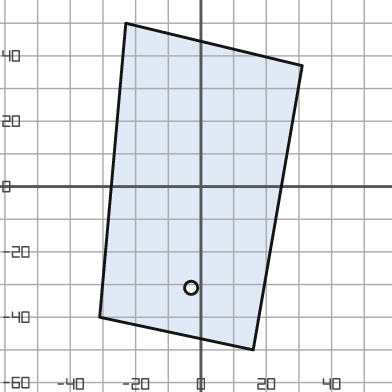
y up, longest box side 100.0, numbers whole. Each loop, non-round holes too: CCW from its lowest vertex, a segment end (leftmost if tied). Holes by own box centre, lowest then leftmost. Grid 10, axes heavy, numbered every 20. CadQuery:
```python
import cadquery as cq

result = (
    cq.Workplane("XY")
    .moveTo(16.0, -50.0)
    .lineTo(31.0, 37.0)
    .lineTo(-23.0, 50.0)
    .lineTo(-31.0, -40.0)
    .close()
    .moveTo(-3.0, -31.0)
    .circle(2.0)
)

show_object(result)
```